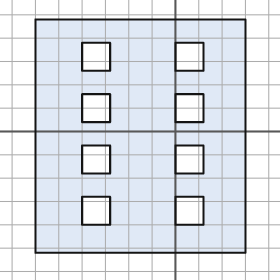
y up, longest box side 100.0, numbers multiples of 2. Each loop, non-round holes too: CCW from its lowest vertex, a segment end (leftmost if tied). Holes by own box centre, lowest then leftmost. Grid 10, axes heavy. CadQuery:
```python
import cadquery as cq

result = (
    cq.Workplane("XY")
    .moveTo(-60.0, -52.0)
    .lineTo(30.0, -52.0)
    .lineTo(30.0, 48.0)
    .lineTo(-60.0, 48.0)
    .close()
    .moveTo(-40.0, -40.0)
    .lineTo(-28.0, -40.0)
    .lineTo(-28.0, -28.0)
    .lineTo(-40.0, -28.0)
    .close()
    .moveTo(0.0, -40.0)
    .lineTo(12.0, -40.0)
    .lineTo(12.0, -28.0)
    .lineTo(0.0, -28.0)
    .close()
    .moveTo(-40.0, -18.0)
    .lineTo(-28.0, -18.0)
    .lineTo(-28.0, -6.0)
    .lineTo(-40.0, -6.0)
    .close()
    .moveTo(0.0, -18.0)
    .lineTo(12.0, -18.0)
    .lineTo(12.0, -6.0)
    .lineTo(0.0, -6.0)
    .close()
    .moveTo(-40.0, 4.0)
    .lineTo(-28.0, 4.0)
    .lineTo(-28.0, 16.0)
    .lineTo(-40.0, 16.0)
    .close()
    .moveTo(0.0, 4.0)
    .lineTo(12.0, 4.0)
    .lineTo(12.0, 16.0)
    .lineTo(0.0, 16.0)
    .close()
    .moveTo(-40.0, 26.0)
    .lineTo(-28.0, 26.0)
    .lineTo(-28.0, 38.0)
    .lineTo(-40.0, 38.0)
    .close()
    .moveTo(0.0, 26.0)
    .lineTo(12.0, 26.0)
    .lineTo(12.0, 38.0)
    .lineTo(0.0, 38.0)
    .close()
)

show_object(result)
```